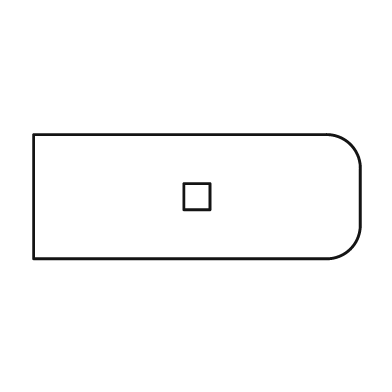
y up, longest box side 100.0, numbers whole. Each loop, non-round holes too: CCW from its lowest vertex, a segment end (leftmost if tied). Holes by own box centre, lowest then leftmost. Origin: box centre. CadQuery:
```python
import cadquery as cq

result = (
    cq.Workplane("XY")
    .moveTo(-50.0, -19.0)
    .lineTo(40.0, -19.0)
    .threePointArc((47.0, -16.0), (50.0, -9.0))
    .lineTo(50.0, 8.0)
    .threePointArc((47.0, 16.0), (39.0, 19.0))
    .lineTo(-50.0, 19.0)
    .close()
    .moveTo(-4.0, -4.0)
    .lineTo(4.0, -4.0)
    .lineTo(4.0, 4.0)
    .lineTo(-4.0, 4.0)
    .close()
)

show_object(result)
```